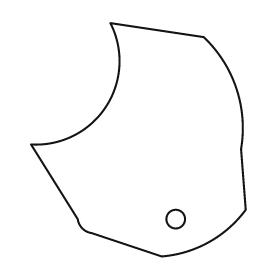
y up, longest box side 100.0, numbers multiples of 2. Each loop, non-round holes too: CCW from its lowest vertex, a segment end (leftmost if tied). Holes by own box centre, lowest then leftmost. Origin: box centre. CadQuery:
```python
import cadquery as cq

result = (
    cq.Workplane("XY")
    .moveTo(10.0, -50.0)
    .threePointArc((30.0, -44.0), (46.0, -30.0))
    .lineTo(44.0, -4.0)
    .threePointArc((42.0, 22.0), (28.0, 44.0))
    .lineTo(-12.0, 50.0)
    .threePointArc((-14.0, 14.0), (-46.0, -2.0))
    .lineTo(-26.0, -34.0)
    .threePointArc((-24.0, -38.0), (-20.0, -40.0))
    .close()
    .moveTo(16.0, -34.0)
    .circle(4.0)
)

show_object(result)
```